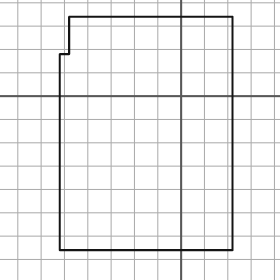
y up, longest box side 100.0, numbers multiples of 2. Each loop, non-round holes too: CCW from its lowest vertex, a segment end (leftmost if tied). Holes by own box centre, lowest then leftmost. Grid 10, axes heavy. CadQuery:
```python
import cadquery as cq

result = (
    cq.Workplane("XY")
    .moveTo(-52.0, -66.0)
    .lineTo(22.0, -66.0)
    .lineTo(22.0, 34.0)
    .lineTo(-48.0, 34.0)
    .lineTo(-48.0, 18.0)
    .lineTo(-52.0, 18.0)
    .close()
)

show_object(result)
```